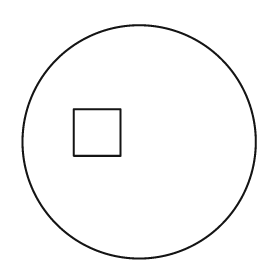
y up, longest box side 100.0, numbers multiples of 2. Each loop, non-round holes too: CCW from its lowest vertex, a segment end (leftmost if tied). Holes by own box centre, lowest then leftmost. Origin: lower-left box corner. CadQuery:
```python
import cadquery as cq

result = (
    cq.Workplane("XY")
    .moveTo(50.0, 50.0)
    .circle(50.0)
    .moveTo(22.0, 44.0)
    .lineTo(42.0, 44.0)
    .lineTo(42.0, 64.0)
    .lineTo(22.0, 64.0)
    .close()
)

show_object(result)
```